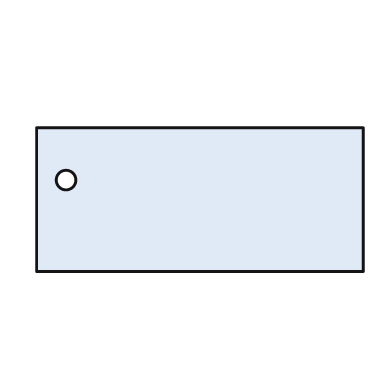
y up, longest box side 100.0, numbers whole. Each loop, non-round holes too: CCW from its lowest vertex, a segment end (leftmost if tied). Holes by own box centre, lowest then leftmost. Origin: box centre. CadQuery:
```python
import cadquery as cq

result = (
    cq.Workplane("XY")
    .moveTo(-50.0, -22.0)
    .lineTo(50.0, -22.0)
    .lineTo(50.0, 22.0)
    .lineTo(-50.0, 22.0)
    .close()
    .moveTo(-41.0, 6.0)
    .circle(3.0)
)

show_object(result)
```